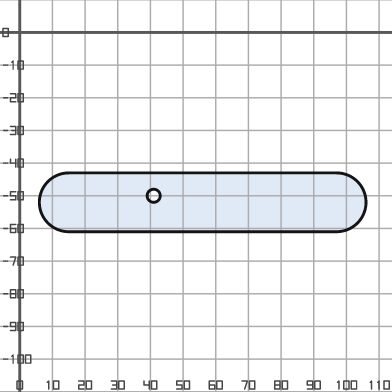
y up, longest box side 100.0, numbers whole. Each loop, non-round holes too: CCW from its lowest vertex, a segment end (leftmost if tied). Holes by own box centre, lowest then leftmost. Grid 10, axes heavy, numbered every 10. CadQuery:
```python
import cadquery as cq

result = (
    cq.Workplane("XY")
    .moveTo(15.0, -61.0)
    .lineTo(97.0, -61.0)
    .threePointArc((106.0, -52.0), (97.0, -43.0))
    .lineTo(15.0, -43.0)
    .threePointArc((6.0, -52.0), (15.0, -61.0))
    .close()
    .moveTo(41.0, -50.0)
    .circle(2.0)
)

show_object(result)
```